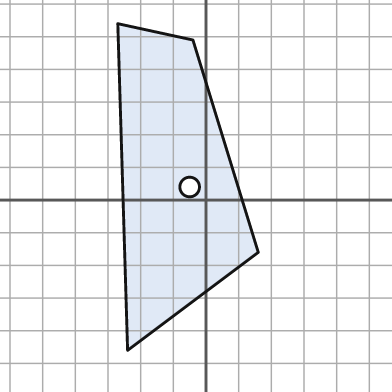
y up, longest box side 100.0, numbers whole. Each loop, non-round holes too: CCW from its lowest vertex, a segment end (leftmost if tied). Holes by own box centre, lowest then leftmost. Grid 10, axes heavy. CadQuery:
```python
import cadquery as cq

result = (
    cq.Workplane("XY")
    .moveTo(-24.0, -46.0)
    .lineTo(16.0, -16.0)
    .lineTo(-4.0, 49.0)
    .lineTo(-27.0, 54.0)
    .close()
    .moveTo(-5.0, 4.0)
    .circle(3.0)
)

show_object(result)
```